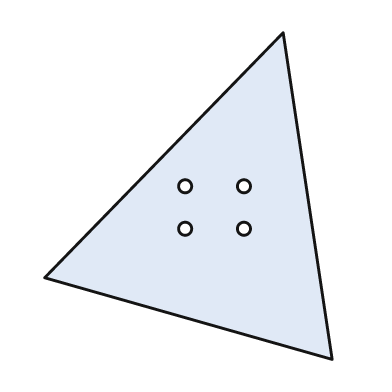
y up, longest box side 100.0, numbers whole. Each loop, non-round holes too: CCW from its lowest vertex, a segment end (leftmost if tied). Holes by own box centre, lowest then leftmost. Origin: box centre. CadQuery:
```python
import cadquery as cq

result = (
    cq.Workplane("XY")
    .moveTo(44.0, -50.0)
    .lineTo(29.0, 50.0)
    .lineTo(-44.0, -25.0)
    .close()
    .moveTo(-1.0, -10.0)
    .circle(2.0)
    .moveTo(17.0, -10.0)
    .circle(2.0)
    .moveTo(-1.0, 3.0)
    .circle(2.0)
    .moveTo(17.0, 3.0)
    .circle(2.0)
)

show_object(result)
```